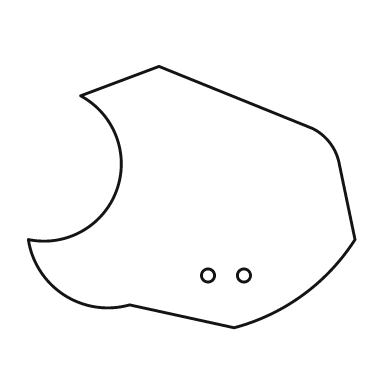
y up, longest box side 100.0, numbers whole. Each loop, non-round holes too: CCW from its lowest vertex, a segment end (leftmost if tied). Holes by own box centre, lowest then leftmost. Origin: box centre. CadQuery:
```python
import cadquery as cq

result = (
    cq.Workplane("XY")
    .moveTo(13.0, -40.0)
    .threePointArc((34.0, -30.0), (50.0, -13.0))
    .lineTo(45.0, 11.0)
    .threePointArc((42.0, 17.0), (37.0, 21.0))
    .lineTo(-10.0, 40.0)
    .lineTo(-34.0, 31.0)
    .threePointArc((-23.0, 2.0), (-50.0, -13.0))
    .threePointArc((-39.0, -30.0), (-19.0, -33.0))
    .close()
    .moveTo(5.0, -24.0)
    .circle(2.0)
    .moveTo(16.0, -24.0)
    .circle(2.0)
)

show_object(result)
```